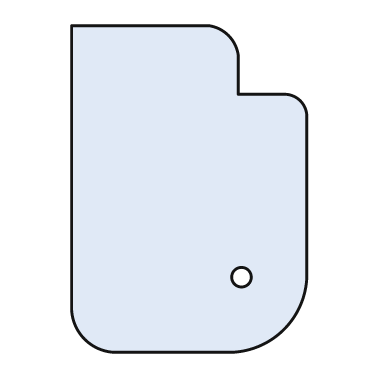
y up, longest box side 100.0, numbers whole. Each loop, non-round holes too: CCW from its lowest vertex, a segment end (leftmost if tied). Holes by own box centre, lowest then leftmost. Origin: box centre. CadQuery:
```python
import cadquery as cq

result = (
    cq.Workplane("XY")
    .moveTo(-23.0, -50.0)
    .lineTo(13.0, -50.0)
    .threePointArc((29.0, -43.0), (36.0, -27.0))
    .lineTo(36.0, 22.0)
    .threePointArc((34.0, 27.0), (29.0, 29.0))
    .lineTo(15.0, 29.0)
    .lineTo(15.0, 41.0)
    .threePointArc((12.0, 47.0), (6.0, 50.0))
    .lineTo(-36.0, 50.0)
    .lineTo(-36.0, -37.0)
    .threePointArc((-32.0, -46.0), (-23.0, -50.0))
    .close()
    .moveTo(16.0, -27.0)
    .circle(3.0)
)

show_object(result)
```